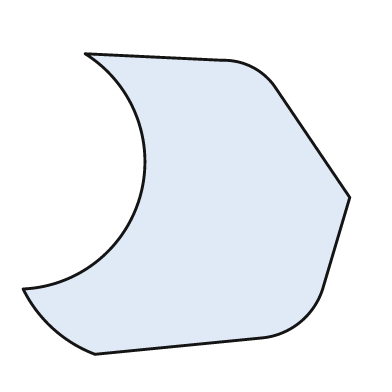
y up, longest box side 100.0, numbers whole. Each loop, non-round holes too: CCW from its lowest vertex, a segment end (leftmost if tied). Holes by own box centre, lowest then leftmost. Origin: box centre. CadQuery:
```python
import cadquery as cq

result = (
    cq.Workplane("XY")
    .moveTo(-28.0, -46.0)
    .lineTo(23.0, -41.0)
    .threePointArc((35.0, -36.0), (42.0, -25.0))
    .lineTo(50.0, 2.0)
    .lineTo(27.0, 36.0)
    .threePointArc((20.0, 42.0), (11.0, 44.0))
    .lineTo(-31.0, 46.0)
    .threePointArc((-14.0, 3.0), (-50.0, -26.0))
    .threePointArc((-41.0, -38.0), (-28.0, -46.0))
    .close()
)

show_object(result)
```